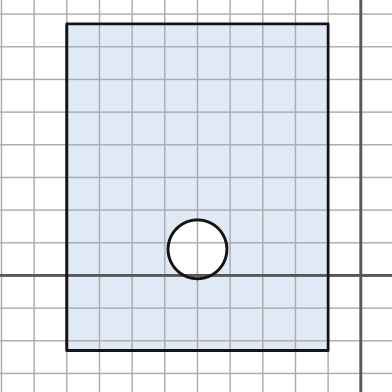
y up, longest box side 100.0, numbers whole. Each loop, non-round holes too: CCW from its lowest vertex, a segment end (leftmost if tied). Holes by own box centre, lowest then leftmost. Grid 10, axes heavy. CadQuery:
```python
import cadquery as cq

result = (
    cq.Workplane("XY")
    .moveTo(-90.0, -23.0)
    .lineTo(-10.0, -23.0)
    .lineTo(-10.0, 77.0)
    .lineTo(-90.0, 77.0)
    .close()
    .moveTo(-50.0, 8.0)
    .circle(9.0)
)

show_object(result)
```